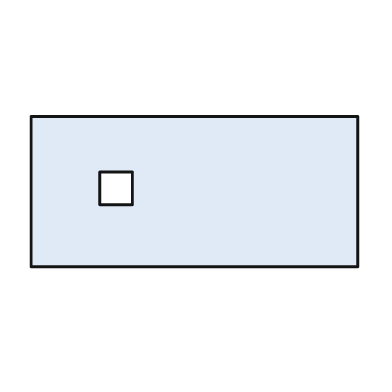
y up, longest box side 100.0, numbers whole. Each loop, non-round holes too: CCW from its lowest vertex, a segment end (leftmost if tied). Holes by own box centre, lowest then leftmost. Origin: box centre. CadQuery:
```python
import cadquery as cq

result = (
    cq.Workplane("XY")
    .moveTo(-50.0, -23.0)
    .lineTo(50.0, -23.0)
    .lineTo(50.0, 23.0)
    .lineTo(-50.0, 23.0)
    .close()
    .moveTo(-29.0, -4.0)
    .lineTo(-19.0, -4.0)
    .lineTo(-19.0, 6.0)
    .lineTo(-29.0, 6.0)
    .close()
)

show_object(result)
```